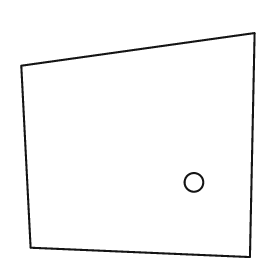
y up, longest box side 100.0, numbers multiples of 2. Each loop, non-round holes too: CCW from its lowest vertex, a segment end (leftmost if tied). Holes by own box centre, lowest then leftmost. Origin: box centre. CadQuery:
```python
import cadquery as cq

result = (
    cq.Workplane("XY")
    .moveTo(48.0, -48.0)
    .lineTo(50.0, 48.0)
    .lineTo(-50.0, 34.0)
    .lineTo(-46.0, -44.0)
    .close()
    .moveTo(24.0, -16.0)
    .circle(4.0)
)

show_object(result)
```